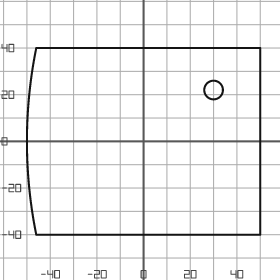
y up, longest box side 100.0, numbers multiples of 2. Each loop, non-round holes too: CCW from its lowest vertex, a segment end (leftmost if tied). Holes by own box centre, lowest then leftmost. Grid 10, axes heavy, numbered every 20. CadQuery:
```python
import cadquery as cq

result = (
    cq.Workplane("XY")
    .moveTo(-46.0, -40.0)
    .lineTo(50.0, -40.0)
    .lineTo(50.0, 40.0)
    .lineTo(-46.0, 40.0)
    .threePointArc((-50.0, 0.0), (-46.0, -40.0))
    .close()
    .moveTo(30.0, 22.0)
    .circle(4.0)
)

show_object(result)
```